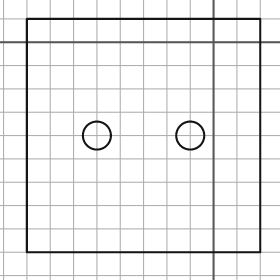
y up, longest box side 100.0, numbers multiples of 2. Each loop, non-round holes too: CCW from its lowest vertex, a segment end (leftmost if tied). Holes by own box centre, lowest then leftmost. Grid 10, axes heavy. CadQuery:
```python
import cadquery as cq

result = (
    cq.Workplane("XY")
    .moveTo(-80.0, -90.0)
    .lineTo(20.0, -90.0)
    .lineTo(20.0, 10.0)
    .lineTo(-80.0, 10.0)
    .close()
    .moveTo(-50.0, -40.0)
    .circle(6.0)
    .moveTo(-10.0, -40.0)
    .circle(6.0)
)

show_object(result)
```